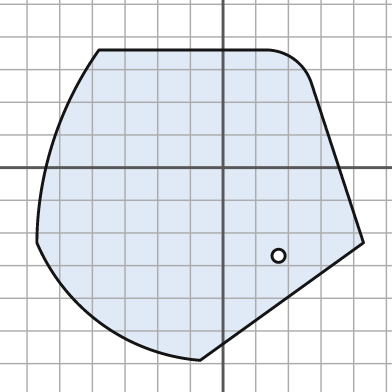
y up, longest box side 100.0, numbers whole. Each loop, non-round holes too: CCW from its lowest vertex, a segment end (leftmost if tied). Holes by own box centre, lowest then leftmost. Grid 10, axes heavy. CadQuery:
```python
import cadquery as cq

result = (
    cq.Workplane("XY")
    .moveTo(-7.0, -59.0)
    .lineTo(43.0, -23.0)
    .lineTo(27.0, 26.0)
    .threePointArc((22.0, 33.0), (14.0, 36.0))
    .lineTo(-38.0, 36.0)
    .threePointArc((-52.0, 8.0), (-57.0, -23.0))
    .threePointArc((-37.0, -48.0), (-7.0, -59.0))
    .close()
    .moveTo(17.0, -27.0)
    .circle(2.0)
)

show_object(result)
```